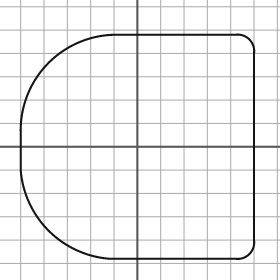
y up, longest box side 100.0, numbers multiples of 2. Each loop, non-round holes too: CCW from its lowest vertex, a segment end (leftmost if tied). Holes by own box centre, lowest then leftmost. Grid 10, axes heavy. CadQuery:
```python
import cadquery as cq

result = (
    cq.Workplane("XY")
    .moveTo(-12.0, -48.0)
    .lineTo(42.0, -48.0)
    .threePointArc((48.0, -46.0), (50.0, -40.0))
    .lineTo(50.0, 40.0)
    .threePointArc((48.0, 46.0), (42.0, 48.0))
    .lineTo(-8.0, 48.0)
    .threePointArc((-38.0, 36.0), (-50.0, 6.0))
    .lineTo(-50.0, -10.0)
    .threePointArc((-38.0, -36.0), (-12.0, -48.0))
    .close()
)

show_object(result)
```